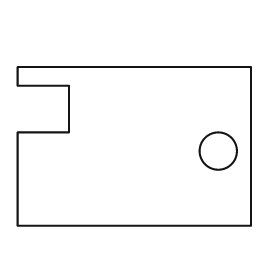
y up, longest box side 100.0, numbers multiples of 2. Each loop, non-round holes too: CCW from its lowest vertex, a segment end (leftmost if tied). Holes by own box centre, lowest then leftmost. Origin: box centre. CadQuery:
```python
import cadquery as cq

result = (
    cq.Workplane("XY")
    .moveTo(-50.0, -34.0)
    .lineTo(50.0, -34.0)
    .lineTo(50.0, 34.0)
    .lineTo(-50.0, 34.0)
    .lineTo(-50.0, 26.0)
    .lineTo(-28.0, 26.0)
    .lineTo(-28.0, 6.0)
    .lineTo(-50.0, 6.0)
    .close()
    .moveTo(36.0, -2.0)
    .circle(8.0)
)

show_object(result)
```